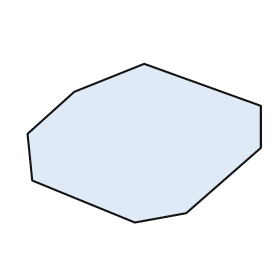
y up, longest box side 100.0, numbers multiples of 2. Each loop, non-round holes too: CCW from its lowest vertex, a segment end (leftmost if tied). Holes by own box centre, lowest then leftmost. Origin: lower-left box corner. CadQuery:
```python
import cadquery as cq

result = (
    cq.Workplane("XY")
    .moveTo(46.0, 0.0)
    .lineTo(68.0, 4.0)
    .lineTo(100.0, 32.0)
    .lineTo(100.0, 50.0)
    .lineTo(50.0, 68.0)
    .lineTo(20.0, 56.0)
    .lineTo(0.0, 38.0)
    .lineTo(2.0, 18.0)
    .close()
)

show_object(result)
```